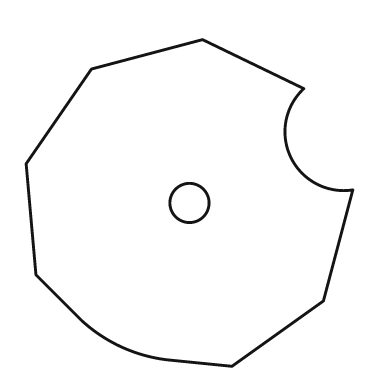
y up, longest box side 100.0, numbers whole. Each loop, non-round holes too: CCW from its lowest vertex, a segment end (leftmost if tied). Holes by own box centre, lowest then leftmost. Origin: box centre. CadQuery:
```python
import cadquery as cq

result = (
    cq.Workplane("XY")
    .moveTo(13.0, -50.0)
    .lineTo(41.0, -30.0)
    .lineTo(50.0, 4.0)
    .threePointArc((31.0, 14.0), (35.0, 35.0))
    .lineTo(4.0, 50.0)
    .lineTo(-30.0, 41.0)
    .lineTo(-50.0, 12.0)
    .lineTo(-47.0, -22.0)
    .lineTo(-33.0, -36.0)
    .threePointArc((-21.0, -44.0), (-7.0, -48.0))
    .close()
    .moveTo(0.0, 0.0)
    .circle(6.0)
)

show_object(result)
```